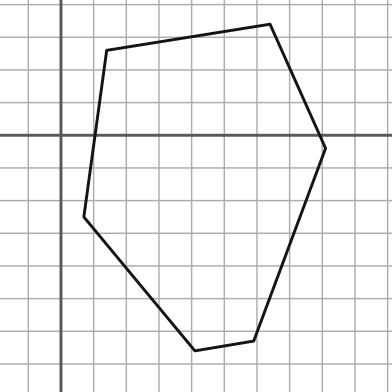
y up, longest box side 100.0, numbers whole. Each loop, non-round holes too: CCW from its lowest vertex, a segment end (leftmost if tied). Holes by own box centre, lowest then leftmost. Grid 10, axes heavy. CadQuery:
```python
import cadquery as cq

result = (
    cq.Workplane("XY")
    .moveTo(41.0, -66.0)
    .lineTo(59.0, -63.0)
    .lineTo(81.0, -4.0)
    .lineTo(64.0, 34.0)
    .lineTo(14.0, 26.0)
    .lineTo(7.0, -25.0)
    .close()
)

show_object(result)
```